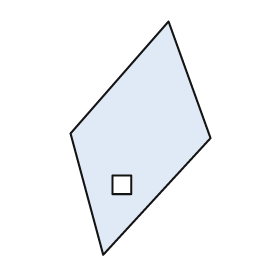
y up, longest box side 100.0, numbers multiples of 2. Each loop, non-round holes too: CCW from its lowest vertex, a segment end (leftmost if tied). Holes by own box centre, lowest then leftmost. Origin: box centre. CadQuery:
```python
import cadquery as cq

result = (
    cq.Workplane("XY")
    .moveTo(-16.0, -50.0)
    .lineTo(30.0, 0.0)
    .lineTo(12.0, 50.0)
    .lineTo(-30.0, 2.0)
    .close()
    .moveTo(-12.0, -24.0)
    .lineTo(-4.0, -24.0)
    .lineTo(-4.0, -16.0)
    .lineTo(-12.0, -16.0)
    .close()
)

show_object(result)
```